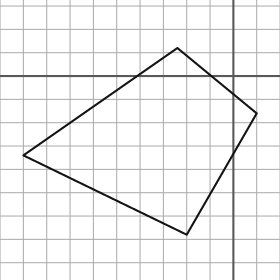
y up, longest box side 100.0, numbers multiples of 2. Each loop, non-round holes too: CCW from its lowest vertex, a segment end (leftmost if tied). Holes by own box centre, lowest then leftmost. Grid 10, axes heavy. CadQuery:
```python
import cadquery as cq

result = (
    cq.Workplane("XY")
    .moveTo(-20.0, -68.0)
    .lineTo(10.0, -16.0)
    .lineTo(-24.0, 12.0)
    .lineTo(-90.0, -34.0)
    .close()
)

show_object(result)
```